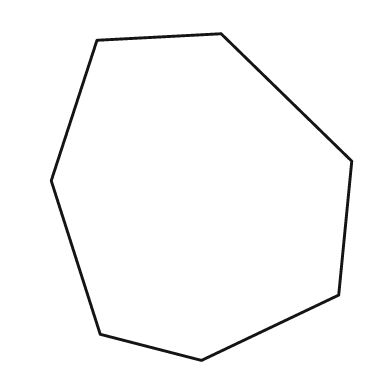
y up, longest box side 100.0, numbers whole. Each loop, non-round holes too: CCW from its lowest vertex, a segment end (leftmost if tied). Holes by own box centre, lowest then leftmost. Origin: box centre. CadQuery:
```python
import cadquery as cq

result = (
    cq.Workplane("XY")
    .moveTo(0.0, -50.0)
    .lineTo(42.0, -30.0)
    .lineTo(46.0, 11.0)
    .lineTo(6.0, 50.0)
    .lineTo(-32.0, 48.0)
    .lineTo(-46.0, 5.0)
    .lineTo(-31.0, -42.0)
    .close()
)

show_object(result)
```